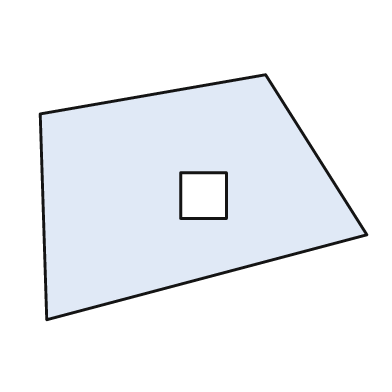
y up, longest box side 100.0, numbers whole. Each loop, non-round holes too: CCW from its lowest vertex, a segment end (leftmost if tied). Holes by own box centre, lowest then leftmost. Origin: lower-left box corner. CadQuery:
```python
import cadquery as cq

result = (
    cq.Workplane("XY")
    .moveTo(2.0, 0.0)
    .lineTo(100.0, 26.0)
    .lineTo(69.0, 75.0)
    .lineTo(0.0, 63.0)
    .close()
    .moveTo(43.0, 31.0)
    .lineTo(57.0, 31.0)
    .lineTo(57.0, 45.0)
    .lineTo(43.0, 45.0)
    .close()
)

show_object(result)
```